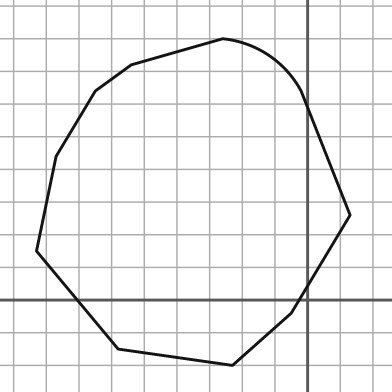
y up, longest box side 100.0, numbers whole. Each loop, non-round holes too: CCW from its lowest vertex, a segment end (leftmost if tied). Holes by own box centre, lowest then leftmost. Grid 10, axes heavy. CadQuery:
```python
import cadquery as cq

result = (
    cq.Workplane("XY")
    .moveTo(-23.0, -20.0)
    .lineTo(-5.0, -4.0)
    .lineTo(13.0, 26.0)
    .lineTo(-2.0, 64.0)
    .threePointArc((-12.0, 75.0), (-26.0, 80.0))
    .lineTo(-54.0, 72.0)
    .lineTo(-65.0, 64.0)
    .lineTo(-77.0, 44.0)
    .lineTo(-83.0, 15.0)
    .lineTo(-58.0, -15.0)
    .close()
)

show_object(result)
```